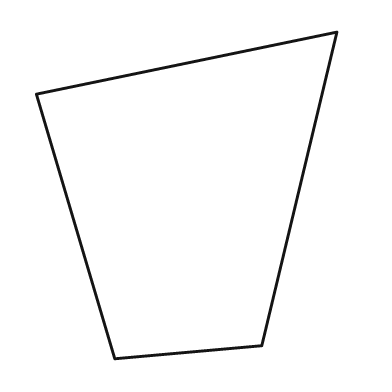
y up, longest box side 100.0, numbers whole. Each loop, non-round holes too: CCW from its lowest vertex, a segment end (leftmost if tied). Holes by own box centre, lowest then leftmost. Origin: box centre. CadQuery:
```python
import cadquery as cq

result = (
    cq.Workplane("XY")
    .moveTo(-22.0, -50.0)
    .lineTo(23.0, -46.0)
    .lineTo(46.0, 50.0)
    .lineTo(-46.0, 31.0)
    .close()
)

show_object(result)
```